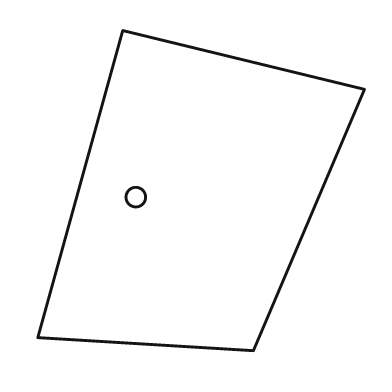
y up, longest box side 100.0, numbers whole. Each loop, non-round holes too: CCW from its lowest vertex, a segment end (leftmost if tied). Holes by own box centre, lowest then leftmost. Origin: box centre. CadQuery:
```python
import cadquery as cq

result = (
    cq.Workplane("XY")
    .moveTo(16.0, -49.0)
    .lineTo(50.0, 31.0)
    .lineTo(-24.0, 49.0)
    .lineTo(-50.0, -45.0)
    .close()
    .moveTo(-20.0, -2.0)
    .circle(3.0)
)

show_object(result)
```